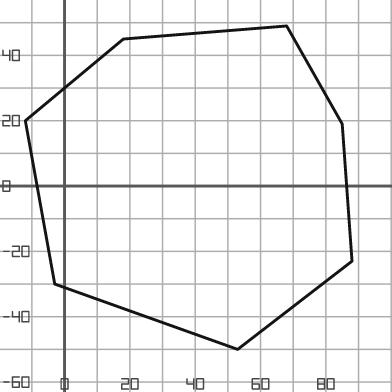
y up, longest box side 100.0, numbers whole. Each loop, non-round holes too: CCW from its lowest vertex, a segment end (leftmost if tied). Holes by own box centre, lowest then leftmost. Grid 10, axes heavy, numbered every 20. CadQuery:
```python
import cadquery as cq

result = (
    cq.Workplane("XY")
    .moveTo(53.0, -50.0)
    .lineTo(88.0, -23.0)
    .lineTo(85.0, 19.0)
    .lineTo(68.0, 49.0)
    .lineTo(18.0, 45.0)
    .lineTo(-12.0, 20.0)
    .lineTo(-3.0, -30.0)
    .close()
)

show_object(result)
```